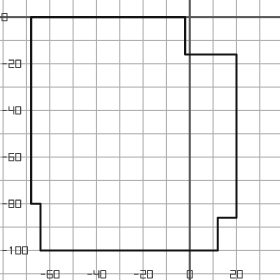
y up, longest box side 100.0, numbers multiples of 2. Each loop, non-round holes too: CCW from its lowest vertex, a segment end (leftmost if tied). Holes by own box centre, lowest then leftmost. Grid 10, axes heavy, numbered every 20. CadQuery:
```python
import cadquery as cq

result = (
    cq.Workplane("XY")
    .moveTo(-64.0, -100.0)
    .lineTo(12.0, -100.0)
    .lineTo(12.0, -86.0)
    .lineTo(20.0, -86.0)
    .lineTo(20.0, -16.0)
    .lineTo(-2.0, -16.0)
    .lineTo(-2.0, 0.0)
    .lineTo(-68.0, 0.0)
    .lineTo(-68.0, -80.0)
    .lineTo(-64.0, -80.0)
    .close()
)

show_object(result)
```